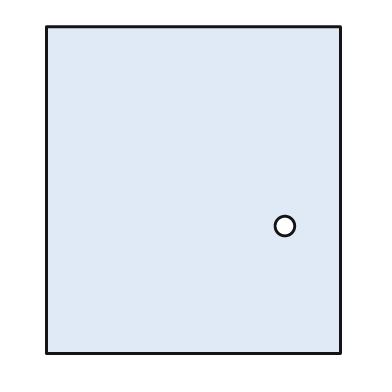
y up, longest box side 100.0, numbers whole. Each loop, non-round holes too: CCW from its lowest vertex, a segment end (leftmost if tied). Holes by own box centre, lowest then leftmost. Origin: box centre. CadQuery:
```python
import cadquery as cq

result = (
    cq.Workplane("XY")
    .moveTo(-45.0, -50.0)
    .lineTo(45.0, -50.0)
    .lineTo(45.0, 50.0)
    .lineTo(-45.0, 50.0)
    .close()
    .moveTo(28.0, -11.0)
    .circle(3.0)
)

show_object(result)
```